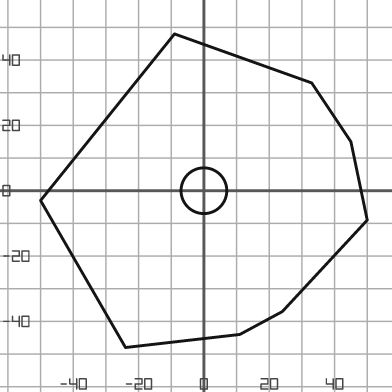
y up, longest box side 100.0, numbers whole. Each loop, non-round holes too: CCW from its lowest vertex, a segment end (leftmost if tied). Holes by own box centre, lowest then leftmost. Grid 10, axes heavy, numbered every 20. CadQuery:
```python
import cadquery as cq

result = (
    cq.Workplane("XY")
    .moveTo(-24.0, -48.0)
    .lineTo(11.0, -44.0)
    .lineTo(24.0, -37.0)
    .lineTo(50.0, -9.0)
    .lineTo(45.0, 15.0)
    .lineTo(33.0, 33.0)
    .lineTo(-9.0, 48.0)
    .lineTo(-50.0, -3.0)
    .close()
    .moveTo(0.0, 0.0)
    .circle(7.0)
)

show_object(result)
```